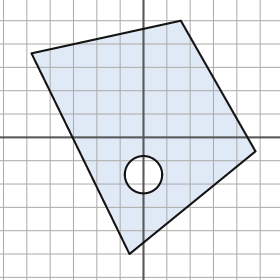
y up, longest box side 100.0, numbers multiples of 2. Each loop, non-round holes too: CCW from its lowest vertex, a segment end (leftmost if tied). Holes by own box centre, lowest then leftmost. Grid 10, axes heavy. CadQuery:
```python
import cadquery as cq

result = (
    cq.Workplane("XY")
    .moveTo(-6.0, -50.0)
    .lineTo(48.0, -6.0)
    .lineTo(16.0, 50.0)
    .lineTo(-48.0, 36.0)
    .close()
    .moveTo(0.0, -16.0)
    .circle(8.0)
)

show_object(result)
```